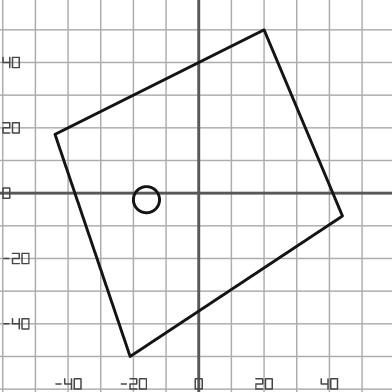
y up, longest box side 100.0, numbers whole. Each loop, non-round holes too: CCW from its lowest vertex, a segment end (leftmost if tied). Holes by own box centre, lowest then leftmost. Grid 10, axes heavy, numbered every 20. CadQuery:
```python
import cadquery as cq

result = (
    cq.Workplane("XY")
    .moveTo(-21.0, -50.0)
    .lineTo(44.0, -7.0)
    .lineTo(20.0, 50.0)
    .lineTo(-44.0, 18.0)
    .close()
    .moveTo(-16.0, -2.0)
    .circle(4.0)
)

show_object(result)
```